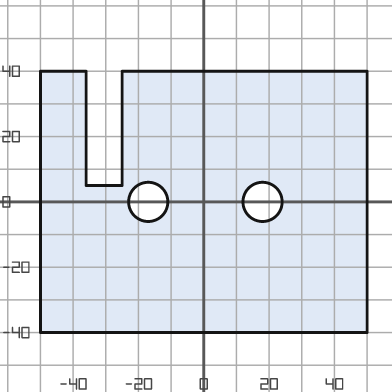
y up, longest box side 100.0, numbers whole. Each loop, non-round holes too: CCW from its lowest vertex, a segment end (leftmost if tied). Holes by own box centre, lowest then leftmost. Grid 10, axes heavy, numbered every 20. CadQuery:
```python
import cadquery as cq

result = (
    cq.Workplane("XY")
    .moveTo(-50.0, -40.0)
    .lineTo(50.0, -40.0)
    .lineTo(50.0, 40.0)
    .lineTo(-25.0, 40.0)
    .lineTo(-25.0, 5.0)
    .lineTo(-36.0, 5.0)
    .lineTo(-36.0, 40.0)
    .lineTo(-50.0, 40.0)
    .close()
    .moveTo(-17.0, 0.0)
    .circle(6.0)
    .moveTo(18.0, 0.0)
    .circle(6.0)
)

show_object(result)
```